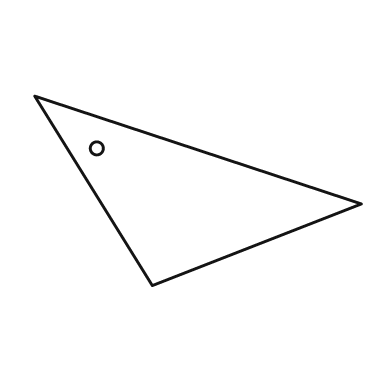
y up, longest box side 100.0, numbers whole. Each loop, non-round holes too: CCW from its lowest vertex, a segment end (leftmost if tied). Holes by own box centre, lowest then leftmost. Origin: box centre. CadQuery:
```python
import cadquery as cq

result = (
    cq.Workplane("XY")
    .moveTo(-14.0, -29.0)
    .lineTo(50.0, -4.0)
    .lineTo(-50.0, 29.0)
    .close()
    .moveTo(-31.0, 13.0)
    .circle(2.0)
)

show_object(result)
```